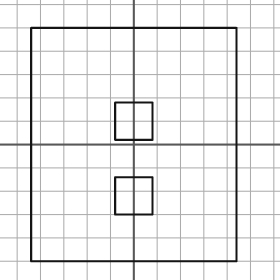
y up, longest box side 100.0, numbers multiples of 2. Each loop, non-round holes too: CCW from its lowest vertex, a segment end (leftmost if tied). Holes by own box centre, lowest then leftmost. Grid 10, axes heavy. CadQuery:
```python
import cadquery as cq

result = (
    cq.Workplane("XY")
    .moveTo(-44.0, -50.0)
    .lineTo(44.0, -50.0)
    .lineTo(44.0, 50.0)
    .lineTo(-44.0, 50.0)
    .close()
    .moveTo(-8.0, -30.0)
    .lineTo(8.0, -30.0)
    .lineTo(8.0, -14.0)
    .lineTo(-8.0, -14.0)
    .close()
    .moveTo(-8.0, 2.0)
    .lineTo(8.0, 2.0)
    .lineTo(8.0, 18.0)
    .lineTo(-8.0, 18.0)
    .close()
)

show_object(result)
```